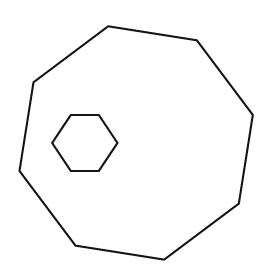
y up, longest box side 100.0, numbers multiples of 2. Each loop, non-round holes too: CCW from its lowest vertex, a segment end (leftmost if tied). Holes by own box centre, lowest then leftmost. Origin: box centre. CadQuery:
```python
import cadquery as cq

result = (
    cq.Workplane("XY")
    .moveTo(12.0, -50.0)
    .lineTo(44.0, -26.0)
    .lineTo(50.0, 12.0)
    .lineTo(26.0, 44.0)
    .lineTo(-12.0, 50.0)
    .lineTo(-44.0, 26.0)
    .lineTo(-50.0, -12.0)
    .lineTo(-26.0, -44.0)
    .close()
    .moveTo(-28.0, -12.0)
    .lineTo(-16.0, -12.0)
    .lineTo(-8.0, 0.0)
    .lineTo(-16.0, 12.0)
    .lineTo(-28.0, 12.0)
    .lineTo(-36.0, 0.0)
    .close()
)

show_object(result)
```